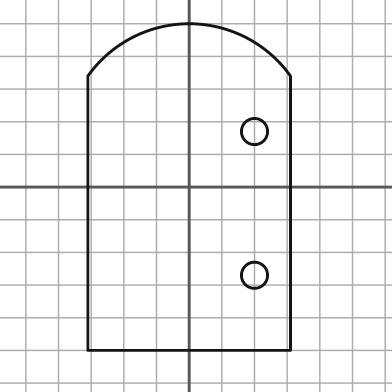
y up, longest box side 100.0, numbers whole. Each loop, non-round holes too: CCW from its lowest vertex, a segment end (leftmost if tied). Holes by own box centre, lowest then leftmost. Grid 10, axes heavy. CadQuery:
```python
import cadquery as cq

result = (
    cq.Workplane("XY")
    .moveTo(-31.0, -50.0)
    .lineTo(31.0, -50.0)
    .lineTo(31.0, 34.0)
    .threePointArc((0.0, 50.0), (-31.0, 34.0))
    .close()
    .moveTo(20.0, -27.0)
    .circle(4.0)
    .moveTo(20.0, 17.0)
    .circle(4.0)
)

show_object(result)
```